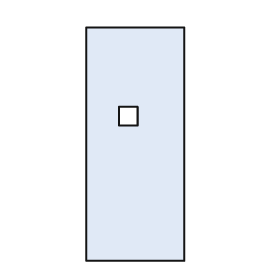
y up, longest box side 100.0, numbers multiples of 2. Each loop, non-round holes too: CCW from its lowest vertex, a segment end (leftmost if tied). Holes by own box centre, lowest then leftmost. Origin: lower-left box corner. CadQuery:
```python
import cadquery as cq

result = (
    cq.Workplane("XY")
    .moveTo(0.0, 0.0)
    .lineTo(42.0, 0.0)
    .lineTo(42.0, 100.0)
    .lineTo(0.0, 100.0)
    .close()
    .moveTo(14.0, 58.0)
    .lineTo(22.0, 58.0)
    .lineTo(22.0, 66.0)
    .lineTo(14.0, 66.0)
    .close()
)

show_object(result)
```